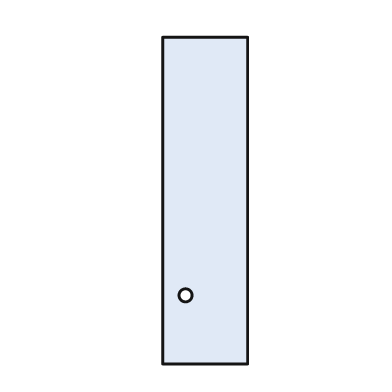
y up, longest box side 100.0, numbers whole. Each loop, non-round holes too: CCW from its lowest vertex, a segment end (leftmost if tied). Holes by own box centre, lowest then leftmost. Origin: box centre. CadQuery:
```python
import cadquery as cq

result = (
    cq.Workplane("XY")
    .moveTo(-13.0, -50.0)
    .lineTo(13.0, -50.0)
    .lineTo(13.0, 50.0)
    .lineTo(-13.0, 50.0)
    .close()
    .moveTo(-6.0, -29.0)
    .circle(2.0)
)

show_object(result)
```